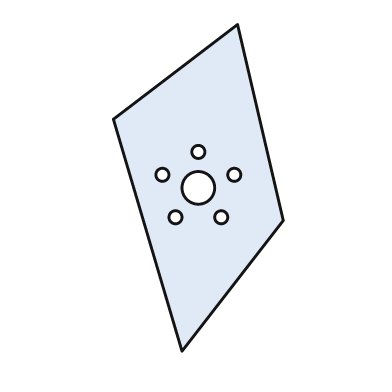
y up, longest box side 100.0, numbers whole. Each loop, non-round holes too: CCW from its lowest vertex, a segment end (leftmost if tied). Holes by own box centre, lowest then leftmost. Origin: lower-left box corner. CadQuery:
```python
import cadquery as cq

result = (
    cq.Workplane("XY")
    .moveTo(21.0, 0.0)
    .lineTo(52.0, 40.0)
    .lineTo(38.0, 100.0)
    .lineTo(0.0, 71.0)
    .close()
    .moveTo(19.0, 41.0)
    .circle(2.0)
    .moveTo(33.0, 41.0)
    .circle(2.0)
    .moveTo(26.0, 50.0)
    .circle(5.0)
    .moveTo(15.0, 54.0)
    .circle(2.0)
    .moveTo(37.0, 54.0)
    .circle(2.0)
    .moveTo(26.0, 61.0)
    .circle(2.0)
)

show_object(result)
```